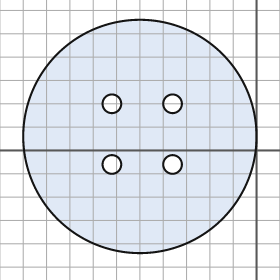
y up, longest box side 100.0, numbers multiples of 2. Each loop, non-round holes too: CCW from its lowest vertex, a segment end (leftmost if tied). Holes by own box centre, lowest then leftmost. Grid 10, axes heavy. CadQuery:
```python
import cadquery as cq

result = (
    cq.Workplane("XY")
    .moveTo(-50.0, 6.0)
    .circle(50.0)
    .moveTo(-62.0, -6.0)
    .circle(4.0)
    .moveTo(-36.0, -6.0)
    .circle(4.0)
    .moveTo(-62.0, 20.0)
    .circle(4.0)
    .moveTo(-36.0, 20.0)
    .circle(4.0)
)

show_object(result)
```